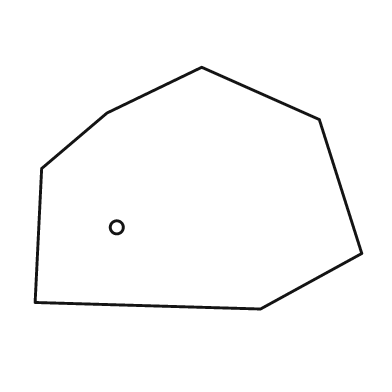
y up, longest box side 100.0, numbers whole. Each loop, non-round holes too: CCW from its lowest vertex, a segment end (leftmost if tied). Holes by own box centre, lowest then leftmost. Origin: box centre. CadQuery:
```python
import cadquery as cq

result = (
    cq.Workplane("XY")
    .moveTo(19.0, -37.0)
    .lineTo(50.0, -20.0)
    .lineTo(37.0, 21.0)
    .lineTo(1.0, 37.0)
    .lineTo(-28.0, 23.0)
    .lineTo(-48.0, 6.0)
    .lineTo(-50.0, -35.0)
    .close()
    .moveTo(-25.0, -12.0)
    .circle(2.0)
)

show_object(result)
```